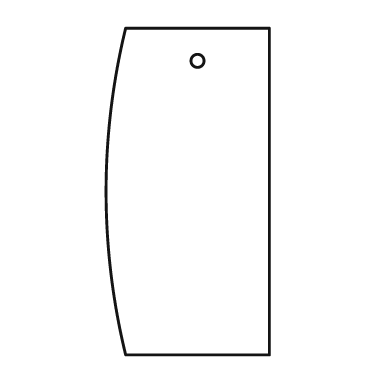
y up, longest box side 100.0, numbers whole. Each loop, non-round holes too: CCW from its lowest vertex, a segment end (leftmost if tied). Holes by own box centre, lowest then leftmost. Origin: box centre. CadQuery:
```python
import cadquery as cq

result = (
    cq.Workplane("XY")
    .moveTo(-19.0, -50.0)
    .lineTo(25.0, -50.0)
    .lineTo(25.0, 50.0)
    .lineTo(-19.0, 50.0)
    .threePointArc((-25.0, 0.0), (-19.0, -50.0))
    .close()
    .moveTo(3.0, 40.0)
    .circle(2.0)
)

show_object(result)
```